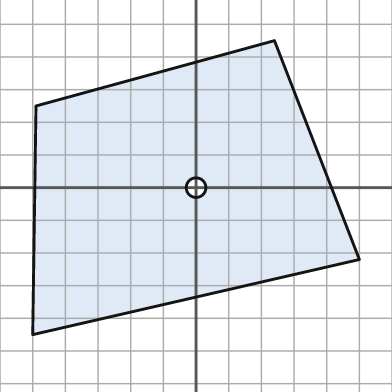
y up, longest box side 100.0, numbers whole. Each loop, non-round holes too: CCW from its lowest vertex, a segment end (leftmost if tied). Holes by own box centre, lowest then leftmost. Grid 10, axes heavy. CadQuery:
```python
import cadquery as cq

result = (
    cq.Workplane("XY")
    .moveTo(-50.0, -45.0)
    .lineTo(50.0, -22.0)
    .lineTo(24.0, 45.0)
    .lineTo(-49.0, 25.0)
    .close()
    .moveTo(0.0, 0.0)
    .circle(3.0)
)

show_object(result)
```